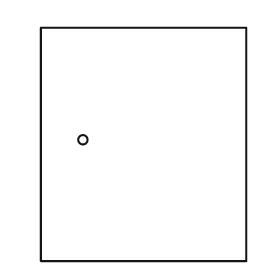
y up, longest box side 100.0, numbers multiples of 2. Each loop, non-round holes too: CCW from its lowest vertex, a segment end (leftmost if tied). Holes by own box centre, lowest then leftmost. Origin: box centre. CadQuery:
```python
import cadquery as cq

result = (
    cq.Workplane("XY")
    .moveTo(-44.0, -50.0)
    .lineTo(44.0, -50.0)
    .lineTo(44.0, 50.0)
    .lineTo(-44.0, 50.0)
    .close()
    .moveTo(-26.0, 2.0)
    .circle(2.0)
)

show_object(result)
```